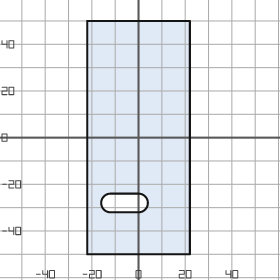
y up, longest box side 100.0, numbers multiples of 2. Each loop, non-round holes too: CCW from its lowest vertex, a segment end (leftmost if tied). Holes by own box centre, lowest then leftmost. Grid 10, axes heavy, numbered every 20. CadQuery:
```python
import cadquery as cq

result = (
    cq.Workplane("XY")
    .moveTo(-22.0, -50.0)
    .lineTo(22.0, -50.0)
    .lineTo(22.0, 50.0)
    .lineTo(-22.0, 50.0)
    .close()
    .moveTo(-12.0, -32.0)
    .lineTo(0.0, -32.0)
    .threePointArc((4.0, -28.0), (0.0, -24.0))
    .lineTo(-12.0, -24.0)
    .threePointArc((-16.0, -28.0), (-12.0, -32.0))
    .close()
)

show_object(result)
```